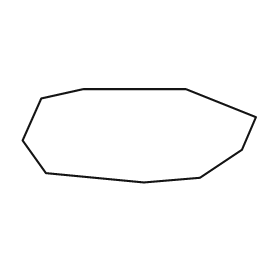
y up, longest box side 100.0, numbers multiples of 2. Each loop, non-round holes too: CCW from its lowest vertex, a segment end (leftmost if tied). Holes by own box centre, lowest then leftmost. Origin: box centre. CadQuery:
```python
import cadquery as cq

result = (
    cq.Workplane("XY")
    .moveTo(2.0, -20.0)
    .lineTo(26.0, -18.0)
    .lineTo(44.0, -6.0)
    .lineTo(50.0, 8.0)
    .lineTo(20.0, 20.0)
    .lineTo(-24.0, 20.0)
    .lineTo(-42.0, 16.0)
    .lineTo(-50.0, -2.0)
    .lineTo(-40.0, -16.0)
    .close()
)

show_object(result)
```